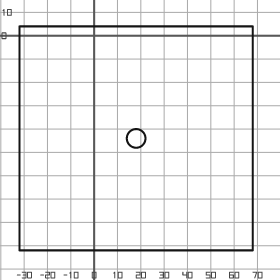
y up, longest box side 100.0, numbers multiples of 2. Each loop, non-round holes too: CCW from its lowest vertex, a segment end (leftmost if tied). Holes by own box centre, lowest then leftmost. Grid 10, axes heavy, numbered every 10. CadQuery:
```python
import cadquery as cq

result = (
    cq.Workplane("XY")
    .moveTo(-32.0, -92.0)
    .lineTo(68.0, -92.0)
    .lineTo(68.0, 4.0)
    .lineTo(-32.0, 4.0)
    .close()
    .moveTo(18.0, -44.0)
    .circle(4.0)
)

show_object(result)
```